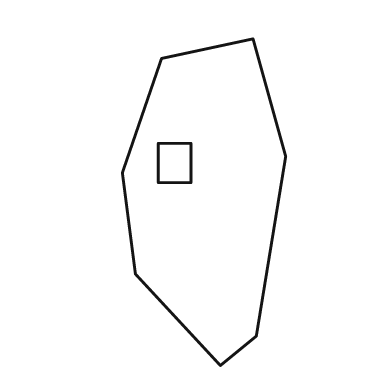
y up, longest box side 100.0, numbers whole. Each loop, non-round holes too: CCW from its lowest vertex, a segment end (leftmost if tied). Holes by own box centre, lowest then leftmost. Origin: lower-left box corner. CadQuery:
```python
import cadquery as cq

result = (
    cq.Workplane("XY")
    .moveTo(30.0, 0.0)
    .lineTo(41.0, 9.0)
    .lineTo(50.0, 64.0)
    .lineTo(40.0, 100.0)
    .lineTo(12.0, 94.0)
    .lineTo(0.0, 59.0)
    .lineTo(4.0, 28.0)
    .close()
    .moveTo(11.0, 56.0)
    .lineTo(21.0, 56.0)
    .lineTo(21.0, 68.0)
    .lineTo(11.0, 68.0)
    .close()
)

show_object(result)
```